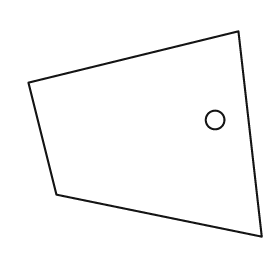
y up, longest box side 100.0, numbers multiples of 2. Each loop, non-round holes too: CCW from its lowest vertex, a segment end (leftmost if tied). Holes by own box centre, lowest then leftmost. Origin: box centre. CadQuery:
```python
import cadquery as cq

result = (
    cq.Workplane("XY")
    .moveTo(50.0, -44.0)
    .lineTo(40.0, 44.0)
    .lineTo(-50.0, 22.0)
    .lineTo(-38.0, -26.0)
    .close()
    .moveTo(30.0, 6.0)
    .circle(4.0)
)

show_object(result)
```